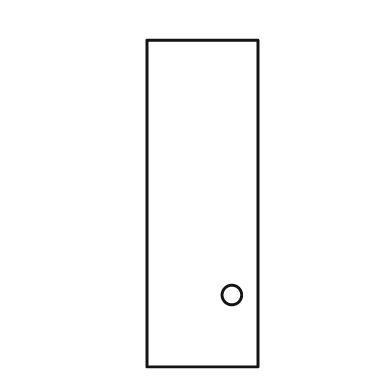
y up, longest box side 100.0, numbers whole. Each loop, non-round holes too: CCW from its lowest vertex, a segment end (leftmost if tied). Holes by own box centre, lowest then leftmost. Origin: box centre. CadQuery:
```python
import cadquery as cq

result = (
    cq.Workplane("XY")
    .moveTo(-17.0, -50.0)
    .lineTo(17.0, -50.0)
    .lineTo(17.0, 50.0)
    .lineTo(-17.0, 50.0)
    .close()
    .moveTo(9.0, -28.0)
    .circle(3.0)
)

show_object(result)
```